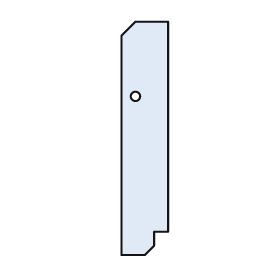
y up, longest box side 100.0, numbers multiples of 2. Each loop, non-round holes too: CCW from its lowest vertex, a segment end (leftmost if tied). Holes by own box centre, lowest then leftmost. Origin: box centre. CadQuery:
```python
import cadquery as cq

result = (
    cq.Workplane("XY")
    .moveTo(-10.0, -50.0)
    .lineTo(0.0, -50.0)
    .lineTo(4.0, -46.0)
    .lineTo(4.0, -40.0)
    .lineTo(10.0, -40.0)
    .lineTo(10.0, 50.0)
    .lineTo(-4.0, 50.0)
    .lineTo(-10.0, 44.0)
    .close()
    .moveTo(-4.0, 18.0)
    .circle(2.0)
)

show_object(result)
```